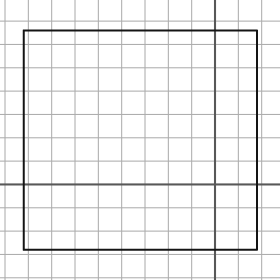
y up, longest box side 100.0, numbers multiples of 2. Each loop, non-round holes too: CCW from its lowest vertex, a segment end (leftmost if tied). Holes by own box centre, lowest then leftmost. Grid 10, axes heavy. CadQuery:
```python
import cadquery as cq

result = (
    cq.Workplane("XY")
    .moveTo(-82.0, -28.0)
    .lineTo(18.0, -28.0)
    .lineTo(18.0, 66.0)
    .lineTo(-82.0, 66.0)
    .close()
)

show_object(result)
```